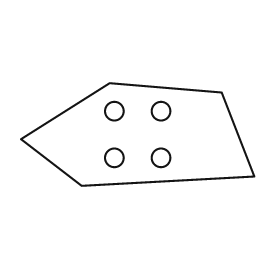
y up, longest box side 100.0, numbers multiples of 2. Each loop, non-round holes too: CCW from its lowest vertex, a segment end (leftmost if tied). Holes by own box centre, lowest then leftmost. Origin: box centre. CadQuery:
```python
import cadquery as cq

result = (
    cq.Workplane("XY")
    .moveTo(-24.0, -22.0)
    .lineTo(50.0, -18.0)
    .lineTo(36.0, 18.0)
    .lineTo(-12.0, 22.0)
    .lineTo(-50.0, -2.0)
    .close()
    .moveTo(-10.0, -10.0)
    .circle(4.0)
    .moveTo(10.0, -10.0)
    .circle(4.0)
    .moveTo(-10.0, 10.0)
    .circle(4.0)
    .moveTo(10.0, 10.0)
    .circle(4.0)
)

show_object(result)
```